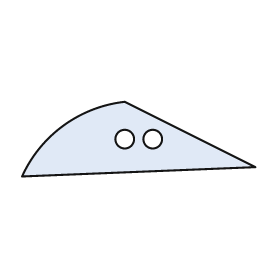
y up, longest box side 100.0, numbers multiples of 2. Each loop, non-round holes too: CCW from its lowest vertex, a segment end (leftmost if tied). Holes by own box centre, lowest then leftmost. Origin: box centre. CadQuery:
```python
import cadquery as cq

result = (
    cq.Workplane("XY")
    .moveTo(-50.0, -16.0)
    .lineTo(50.0, -12.0)
    .lineTo(-6.0, 16.0)
    .threePointArc((-32.0, 6.0), (-50.0, -16.0))
    .close()
    .moveTo(-6.0, 0.0)
    .circle(4.0)
    .moveTo(6.0, 0.0)
    .circle(4.0)
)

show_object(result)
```